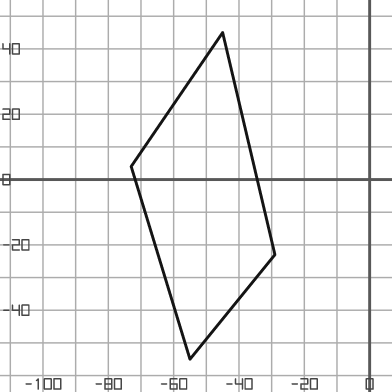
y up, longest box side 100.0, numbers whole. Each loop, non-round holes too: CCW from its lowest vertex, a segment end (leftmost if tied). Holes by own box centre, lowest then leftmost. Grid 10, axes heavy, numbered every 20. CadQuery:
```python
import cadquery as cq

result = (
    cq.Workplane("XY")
    .moveTo(-55.0, -55.0)
    .lineTo(-29.0, -23.0)
    .lineTo(-45.0, 45.0)
    .lineTo(-73.0, 4.0)
    .close()
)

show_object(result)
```